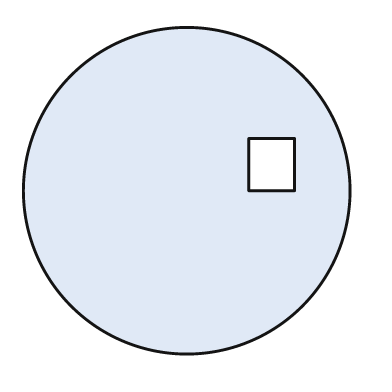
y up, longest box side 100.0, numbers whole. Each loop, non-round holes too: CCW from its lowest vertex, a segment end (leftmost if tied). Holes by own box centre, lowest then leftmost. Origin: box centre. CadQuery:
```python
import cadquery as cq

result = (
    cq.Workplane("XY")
    .moveTo(0.0, 0.0)
    .circle(50.0)
    .moveTo(19.0, 0.0)
    .lineTo(33.0, 0.0)
    .lineTo(33.0, 16.0)
    .lineTo(19.0, 16.0)
    .close()
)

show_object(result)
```